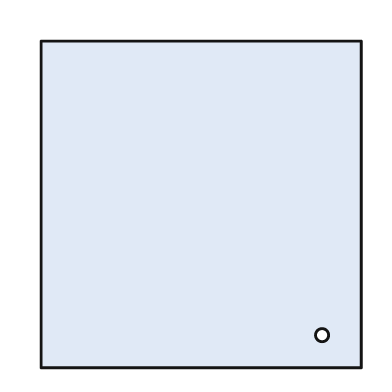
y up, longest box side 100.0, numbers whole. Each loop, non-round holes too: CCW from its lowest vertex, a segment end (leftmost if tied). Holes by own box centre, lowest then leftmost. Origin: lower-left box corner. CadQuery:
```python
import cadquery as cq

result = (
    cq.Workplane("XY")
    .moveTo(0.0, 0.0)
    .lineTo(98.0, 0.0)
    .lineTo(98.0, 100.0)
    .lineTo(0.0, 100.0)
    .close()
    .moveTo(86.0, 10.0)
    .circle(2.0)
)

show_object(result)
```